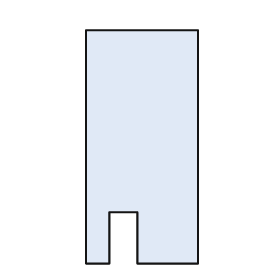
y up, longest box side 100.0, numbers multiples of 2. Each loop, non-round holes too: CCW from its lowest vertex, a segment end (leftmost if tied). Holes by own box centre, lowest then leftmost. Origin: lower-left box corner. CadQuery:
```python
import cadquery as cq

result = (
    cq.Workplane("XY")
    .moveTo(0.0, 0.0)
    .lineTo(10.0, 0.0)
    .lineTo(10.0, 22.0)
    .lineTo(22.0, 22.0)
    .lineTo(22.0, 0.0)
    .lineTo(48.0, 0.0)
    .lineTo(48.0, 100.0)
    .lineTo(0.0, 100.0)
    .close()
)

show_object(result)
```